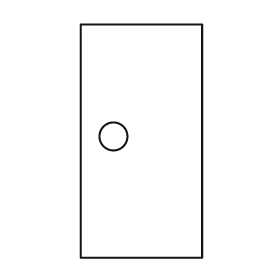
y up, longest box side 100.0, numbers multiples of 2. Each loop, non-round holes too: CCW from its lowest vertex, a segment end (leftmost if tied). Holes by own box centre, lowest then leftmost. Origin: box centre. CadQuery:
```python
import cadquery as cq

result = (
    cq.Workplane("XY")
    .moveTo(-26.0, -50.0)
    .lineTo(26.0, -50.0)
    .lineTo(26.0, 50.0)
    .lineTo(-26.0, 50.0)
    .close()
    .moveTo(-12.0, 2.0)
    .circle(6.0)
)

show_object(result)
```